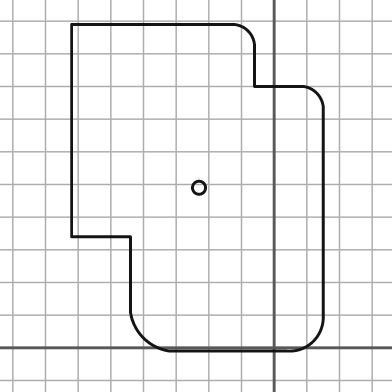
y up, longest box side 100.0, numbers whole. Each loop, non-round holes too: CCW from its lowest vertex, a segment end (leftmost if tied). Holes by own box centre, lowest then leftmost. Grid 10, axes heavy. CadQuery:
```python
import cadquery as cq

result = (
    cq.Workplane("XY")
    .moveTo(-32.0, -1.0)
    .lineTo(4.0, -1.0)
    .threePointArc((12.0, 2.0), (15.0, 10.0))
    .lineTo(15.0, 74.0)
    .threePointArc((13.0, 78.0), (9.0, 80.0))
    .lineTo(-6.0, 80.0)
    .lineTo(-6.0, 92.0)
    .threePointArc((-8.0, 97.0), (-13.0, 99.0))
    .lineTo(-62.0, 99.0)
    .lineTo(-62.0, 34.0)
    .lineTo(-44.0, 34.0)
    .lineTo(-44.0, 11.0)
    .threePointArc((-40.0, 3.0), (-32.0, -1.0))
    .close()
    .moveTo(-23.0, 49.0)
    .circle(2.0)
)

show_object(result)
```